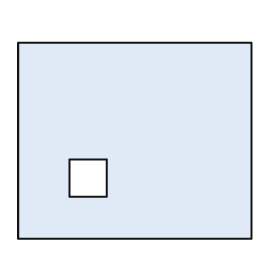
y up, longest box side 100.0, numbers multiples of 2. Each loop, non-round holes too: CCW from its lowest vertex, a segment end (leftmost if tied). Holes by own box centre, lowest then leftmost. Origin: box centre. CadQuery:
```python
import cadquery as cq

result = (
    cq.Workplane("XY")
    .moveTo(-50.0, -42.0)
    .lineTo(50.0, -42.0)
    .lineTo(50.0, 42.0)
    .lineTo(-50.0, 42.0)
    .close()
    .moveTo(-28.0, -24.0)
    .lineTo(-12.0, -24.0)
    .lineTo(-12.0, -8.0)
    .lineTo(-28.0, -8.0)
    .close()
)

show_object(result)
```